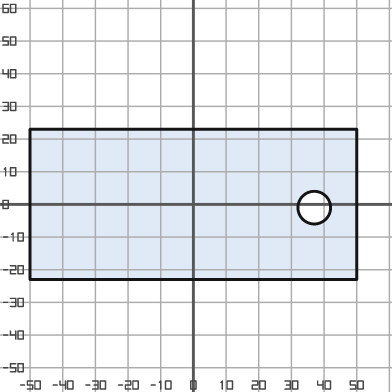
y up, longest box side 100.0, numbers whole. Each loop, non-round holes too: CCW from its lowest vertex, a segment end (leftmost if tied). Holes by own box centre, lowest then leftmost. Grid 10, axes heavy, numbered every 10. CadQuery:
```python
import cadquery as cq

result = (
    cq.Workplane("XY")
    .moveTo(-50.0, -23.0)
    .lineTo(50.0, -23.0)
    .lineTo(50.0, 23.0)
    .lineTo(-50.0, 23.0)
    .close()
    .moveTo(37.0, -1.0)
    .circle(5.0)
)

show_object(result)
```